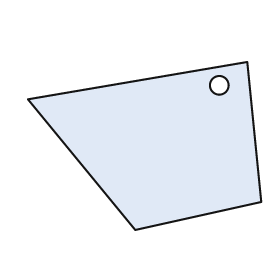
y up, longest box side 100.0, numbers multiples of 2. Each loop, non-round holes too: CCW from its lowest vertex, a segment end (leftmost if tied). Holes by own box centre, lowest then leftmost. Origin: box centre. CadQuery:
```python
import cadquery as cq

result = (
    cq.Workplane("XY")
    .moveTo(-4.0, -36.0)
    .lineTo(50.0, -24.0)
    .lineTo(44.0, 36.0)
    .lineTo(-50.0, 20.0)
    .close()
    .moveTo(32.0, 26.0)
    .circle(4.0)
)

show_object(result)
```